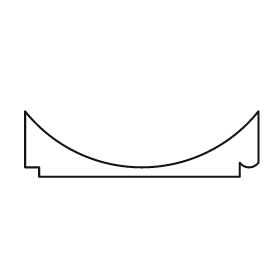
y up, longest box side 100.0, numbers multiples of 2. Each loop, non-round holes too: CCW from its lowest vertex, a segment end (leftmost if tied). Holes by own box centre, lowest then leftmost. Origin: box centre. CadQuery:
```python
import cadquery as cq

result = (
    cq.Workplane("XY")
    .moveTo(-44.0, -14.0)
    .lineTo(42.0, -14.0)
    .lineTo(42.0, -8.0)
    .threePointArc((46.0, -10.0), (50.0, -8.0))
    .lineTo(50.0, 14.0)
    .threePointArc((0.0, -10.0), (-50.0, 14.0))
    .lineTo(-50.0, -10.0)
    .lineTo(-44.0, -10.0)
    .close()
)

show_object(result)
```